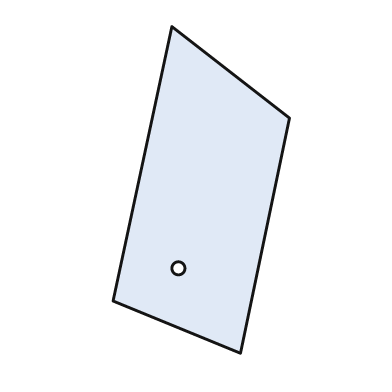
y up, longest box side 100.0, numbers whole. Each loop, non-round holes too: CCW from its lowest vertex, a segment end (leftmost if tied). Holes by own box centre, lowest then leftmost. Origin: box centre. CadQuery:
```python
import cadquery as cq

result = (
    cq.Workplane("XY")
    .moveTo(12.0, -50.0)
    .lineTo(27.0, 22.0)
    .lineTo(-9.0, 50.0)
    .lineTo(-27.0, -34.0)
    .close()
    .moveTo(-7.0, -24.0)
    .circle(2.0)
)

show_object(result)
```